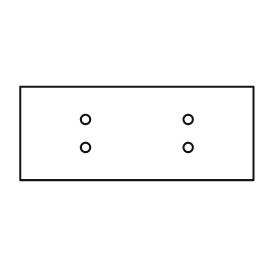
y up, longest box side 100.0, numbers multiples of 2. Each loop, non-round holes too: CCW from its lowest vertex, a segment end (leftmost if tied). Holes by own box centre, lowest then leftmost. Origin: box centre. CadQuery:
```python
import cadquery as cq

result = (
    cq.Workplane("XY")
    .moveTo(-50.0, -20.0)
    .lineTo(50.0, -20.0)
    .lineTo(50.0, 20.0)
    .lineTo(-50.0, 20.0)
    .close()
    .moveTo(-22.0, -6.0)
    .circle(2.0)
    .moveTo(22.0, -6.0)
    .circle(2.0)
    .moveTo(-22.0, 6.0)
    .circle(2.0)
    .moveTo(22.0, 6.0)
    .circle(2.0)
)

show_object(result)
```